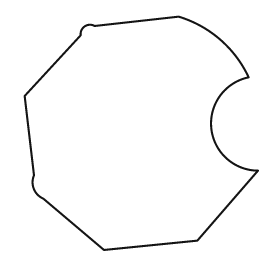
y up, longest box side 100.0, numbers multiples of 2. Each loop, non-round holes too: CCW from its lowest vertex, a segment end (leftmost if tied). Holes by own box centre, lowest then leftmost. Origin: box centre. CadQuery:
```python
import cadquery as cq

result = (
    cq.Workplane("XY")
    .moveTo(-16.0, -50.0)
    .lineTo(24.0, -46.0)
    .lineTo(50.0, -16.0)
    .threePointArc((30.0, 2.0), (46.0, 24.0))
    .threePointArc((34.0, 40.0), (16.0, 50.0))
    .lineTo(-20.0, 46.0)
    .threePointArc((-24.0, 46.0), (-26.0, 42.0))
    .lineTo(-50.0, 16.0)
    .lineTo(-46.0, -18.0)
    .threePointArc((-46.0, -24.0), (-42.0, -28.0))
    .close()
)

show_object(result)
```